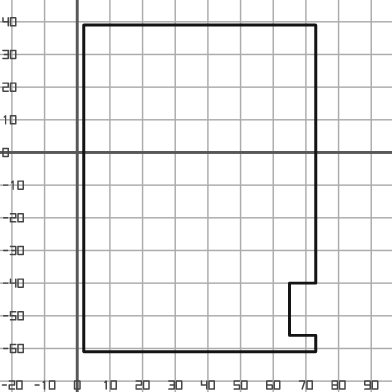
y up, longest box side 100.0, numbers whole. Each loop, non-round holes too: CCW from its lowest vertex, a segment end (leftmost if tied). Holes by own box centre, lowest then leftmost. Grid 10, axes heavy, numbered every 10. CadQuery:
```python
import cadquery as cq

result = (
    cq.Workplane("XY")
    .moveTo(2.0, -61.0)
    .lineTo(73.0, -61.0)
    .lineTo(73.0, -56.0)
    .lineTo(65.0, -56.0)
    .lineTo(65.0, -40.0)
    .lineTo(73.0, -40.0)
    .lineTo(73.0, 39.0)
    .lineTo(2.0, 39.0)
    .close()
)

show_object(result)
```